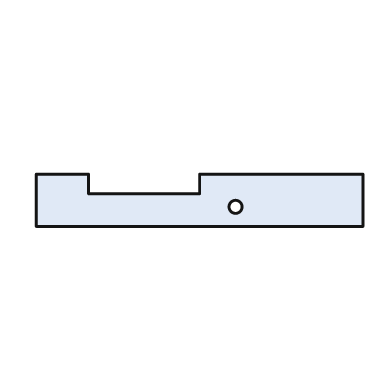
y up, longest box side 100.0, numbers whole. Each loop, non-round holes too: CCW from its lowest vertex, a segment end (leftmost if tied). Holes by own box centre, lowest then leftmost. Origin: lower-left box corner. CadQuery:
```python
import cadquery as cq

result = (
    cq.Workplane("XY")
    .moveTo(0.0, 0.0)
    .lineTo(100.0, 0.0)
    .lineTo(100.0, 16.0)
    .lineTo(50.0, 16.0)
    .lineTo(50.0, 10.0)
    .lineTo(16.0, 10.0)
    .lineTo(16.0, 16.0)
    .lineTo(0.0, 16.0)
    .close()
    .moveTo(61.0, 6.0)
    .circle(2.0)
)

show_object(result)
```